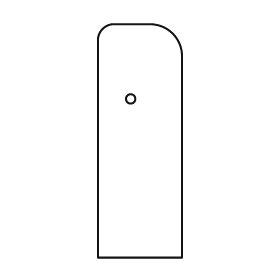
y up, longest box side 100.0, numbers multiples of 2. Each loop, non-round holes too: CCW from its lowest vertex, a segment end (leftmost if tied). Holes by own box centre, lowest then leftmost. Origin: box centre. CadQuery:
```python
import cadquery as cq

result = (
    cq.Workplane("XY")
    .moveTo(-18.0, -50.0)
    .lineTo(18.0, -50.0)
    .lineTo(18.0, 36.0)
    .threePointArc((14.0, 46.0), (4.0, 50.0))
    .lineTo(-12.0, 50.0)
    .threePointArc((-16.0, 48.0), (-18.0, 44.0))
    .close()
    .moveTo(-4.0, 18.0)
    .circle(2.0)
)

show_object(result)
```